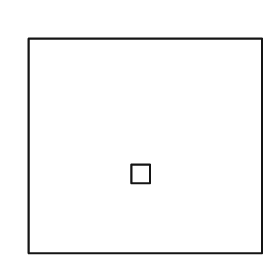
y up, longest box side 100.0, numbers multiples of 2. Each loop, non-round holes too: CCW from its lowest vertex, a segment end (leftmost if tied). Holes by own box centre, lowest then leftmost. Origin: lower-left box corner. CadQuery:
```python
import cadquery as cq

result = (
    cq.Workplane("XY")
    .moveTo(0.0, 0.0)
    .lineTo(100.0, 0.0)
    .lineTo(100.0, 92.0)
    .lineTo(0.0, 92.0)
    .close()
    .moveTo(44.0, 30.0)
    .lineTo(52.0, 30.0)
    .lineTo(52.0, 38.0)
    .lineTo(44.0, 38.0)
    .close()
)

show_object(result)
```